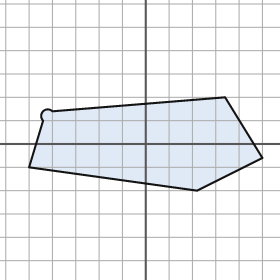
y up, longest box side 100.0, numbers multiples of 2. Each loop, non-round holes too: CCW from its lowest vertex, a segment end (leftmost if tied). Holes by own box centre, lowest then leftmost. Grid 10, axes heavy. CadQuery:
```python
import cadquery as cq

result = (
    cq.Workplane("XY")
    .moveTo(22.0, -20.0)
    .lineTo(50.0, -6.0)
    .lineTo(34.0, 20.0)
    .lineTo(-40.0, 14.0)
    .threePointArc((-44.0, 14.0), (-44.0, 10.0))
    .lineTo(-50.0, -10.0)
    .close()
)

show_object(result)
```